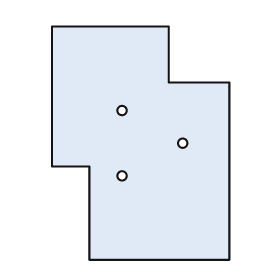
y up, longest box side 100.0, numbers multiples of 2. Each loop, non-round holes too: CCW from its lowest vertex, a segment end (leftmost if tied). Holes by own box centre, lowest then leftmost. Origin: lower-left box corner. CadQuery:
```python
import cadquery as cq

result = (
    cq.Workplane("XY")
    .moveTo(16.0, 0.0)
    .lineTo(76.0, 0.0)
    .lineTo(76.0, 76.0)
    .lineTo(50.0, 76.0)
    .lineTo(50.0, 100.0)
    .lineTo(0.0, 100.0)
    .lineTo(0.0, 40.0)
    .lineTo(16.0, 40.0)
    .close()
    .moveTo(30.0, 36.0)
    .circle(2.0)
    .moveTo(56.0, 50.0)
    .circle(2.0)
    .moveTo(30.0, 64.0)
    .circle(2.0)
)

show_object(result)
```